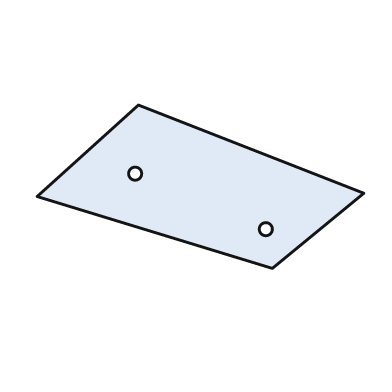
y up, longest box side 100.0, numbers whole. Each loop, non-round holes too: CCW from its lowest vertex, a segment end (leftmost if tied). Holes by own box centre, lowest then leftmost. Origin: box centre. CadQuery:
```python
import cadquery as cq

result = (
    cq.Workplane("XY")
    .moveTo(22.0, -25.0)
    .lineTo(50.0, -2.0)
    .lineTo(-19.0, 25.0)
    .lineTo(-50.0, -3.0)
    .close()
    .moveTo(20.0, -13.0)
    .circle(2.0)
    .moveTo(-20.0, 4.0)
    .circle(2.0)
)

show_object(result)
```